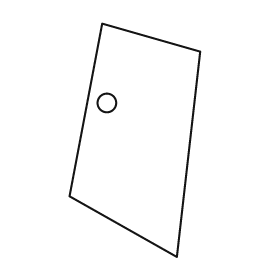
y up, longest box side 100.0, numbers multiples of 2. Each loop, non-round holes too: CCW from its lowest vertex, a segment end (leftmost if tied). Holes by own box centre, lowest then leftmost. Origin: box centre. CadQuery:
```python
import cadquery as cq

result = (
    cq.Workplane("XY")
    .moveTo(18.0, -50.0)
    .lineTo(28.0, 38.0)
    .lineTo(-14.0, 50.0)
    .lineTo(-28.0, -24.0)
    .close()
    .moveTo(-12.0, 16.0)
    .circle(4.0)
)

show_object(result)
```